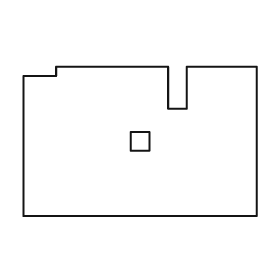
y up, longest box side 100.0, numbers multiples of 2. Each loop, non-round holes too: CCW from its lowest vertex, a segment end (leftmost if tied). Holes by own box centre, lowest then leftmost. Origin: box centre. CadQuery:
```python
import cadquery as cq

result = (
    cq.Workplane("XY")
    .moveTo(-50.0, -32.0)
    .lineTo(50.0, -32.0)
    .lineTo(50.0, 32.0)
    .lineTo(20.0, 32.0)
    .lineTo(20.0, 14.0)
    .lineTo(12.0, 14.0)
    .lineTo(12.0, 32.0)
    .lineTo(-36.0, 32.0)
    .lineTo(-36.0, 28.0)
    .lineTo(-50.0, 28.0)
    .close()
    .moveTo(-4.0, -4.0)
    .lineTo(4.0, -4.0)
    .lineTo(4.0, 4.0)
    .lineTo(-4.0, 4.0)
    .close()
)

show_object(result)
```